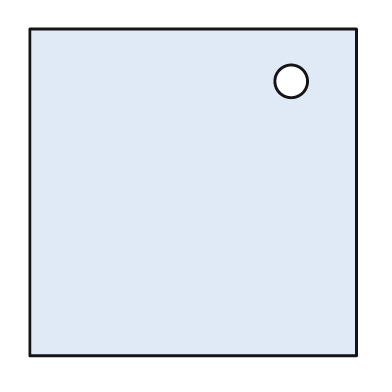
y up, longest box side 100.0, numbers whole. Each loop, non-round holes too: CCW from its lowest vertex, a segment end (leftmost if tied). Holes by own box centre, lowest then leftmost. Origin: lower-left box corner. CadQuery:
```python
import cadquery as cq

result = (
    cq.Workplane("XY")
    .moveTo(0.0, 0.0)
    .lineTo(100.0, 0.0)
    .lineTo(100.0, 100.0)
    .lineTo(0.0, 100.0)
    .close()
    .moveTo(80.0, 84.0)
    .circle(5.0)
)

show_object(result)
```